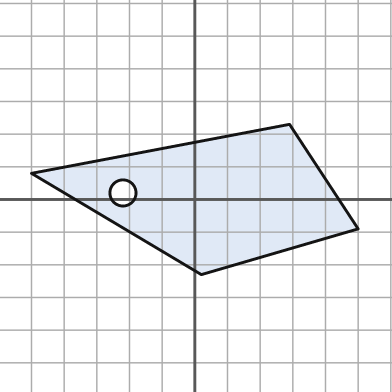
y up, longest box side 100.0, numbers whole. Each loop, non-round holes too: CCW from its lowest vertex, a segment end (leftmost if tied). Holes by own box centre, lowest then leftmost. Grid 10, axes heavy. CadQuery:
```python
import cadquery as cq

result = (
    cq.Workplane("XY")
    .moveTo(2.0, -23.0)
    .lineTo(50.0, -9.0)
    .lineTo(29.0, 23.0)
    .lineTo(-50.0, 8.0)
    .close()
    .moveTo(-22.0, 2.0)
    .circle(4.0)
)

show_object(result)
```